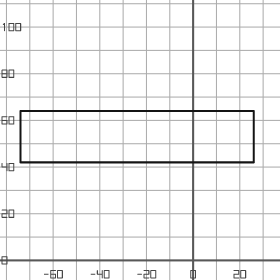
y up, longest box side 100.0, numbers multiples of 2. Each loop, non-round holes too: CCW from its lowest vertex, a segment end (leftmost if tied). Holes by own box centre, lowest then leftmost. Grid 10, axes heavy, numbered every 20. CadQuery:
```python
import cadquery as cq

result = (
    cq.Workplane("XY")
    .moveTo(-74.0, 42.0)
    .lineTo(26.0, 42.0)
    .lineTo(26.0, 64.0)
    .lineTo(-74.0, 64.0)
    .close()
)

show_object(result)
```